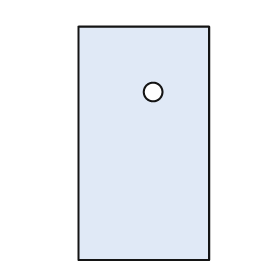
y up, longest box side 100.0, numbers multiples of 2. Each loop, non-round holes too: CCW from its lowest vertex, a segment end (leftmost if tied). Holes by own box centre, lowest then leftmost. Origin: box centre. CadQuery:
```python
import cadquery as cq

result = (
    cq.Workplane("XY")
    .moveTo(-28.0, -50.0)
    .lineTo(28.0, -50.0)
    .lineTo(28.0, 50.0)
    .lineTo(-28.0, 50.0)
    .close()
    .moveTo(4.0, 22.0)
    .circle(4.0)
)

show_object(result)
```